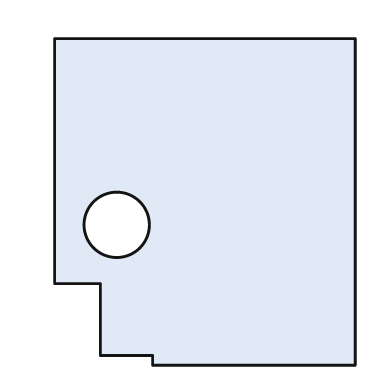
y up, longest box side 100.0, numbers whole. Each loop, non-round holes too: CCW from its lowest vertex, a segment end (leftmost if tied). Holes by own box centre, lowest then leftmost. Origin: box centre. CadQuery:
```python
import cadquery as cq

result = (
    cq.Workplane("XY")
    .moveTo(-16.0, -50.0)
    .lineTo(46.0, -50.0)
    .lineTo(46.0, 50.0)
    .lineTo(-46.0, 50.0)
    .lineTo(-46.0, -25.0)
    .lineTo(-32.0, -25.0)
    .lineTo(-32.0, -47.0)
    .lineTo(-16.0, -47.0)
    .close()
    .moveTo(-27.0, -7.0)
    .circle(10.0)
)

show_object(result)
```